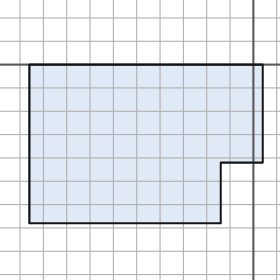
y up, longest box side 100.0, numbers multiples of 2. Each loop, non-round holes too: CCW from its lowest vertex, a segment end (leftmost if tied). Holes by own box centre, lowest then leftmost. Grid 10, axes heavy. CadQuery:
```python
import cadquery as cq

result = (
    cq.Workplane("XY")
    .moveTo(-96.0, -68.0)
    .lineTo(-14.0, -68.0)
    .lineTo(-14.0, -42.0)
    .lineTo(4.0, -42.0)
    .lineTo(4.0, 0.0)
    .lineTo(-96.0, 0.0)
    .close()
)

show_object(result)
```